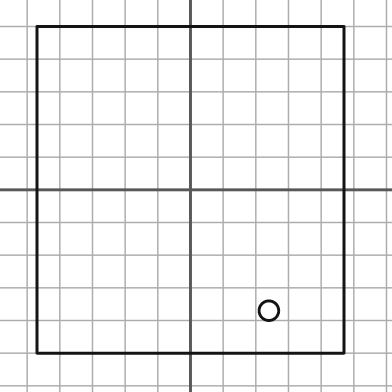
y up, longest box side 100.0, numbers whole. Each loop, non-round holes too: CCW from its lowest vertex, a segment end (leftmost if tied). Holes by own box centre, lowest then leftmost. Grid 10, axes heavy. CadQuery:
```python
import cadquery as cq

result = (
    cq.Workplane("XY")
    .moveTo(-47.0, -50.0)
    .lineTo(47.0, -50.0)
    .lineTo(47.0, 50.0)
    .lineTo(-47.0, 50.0)
    .close()
    .moveTo(24.0, -37.0)
    .circle(3.0)
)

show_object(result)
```